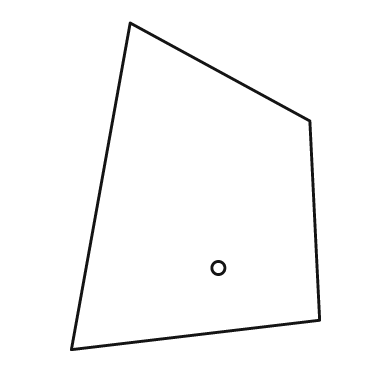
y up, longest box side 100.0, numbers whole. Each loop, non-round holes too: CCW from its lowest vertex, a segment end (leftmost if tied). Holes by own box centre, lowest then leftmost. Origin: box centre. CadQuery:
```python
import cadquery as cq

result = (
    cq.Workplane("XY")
    .moveTo(-38.0, -50.0)
    .lineTo(38.0, -41.0)
    .lineTo(35.0, 20.0)
    .lineTo(-20.0, 50.0)
    .close()
    .moveTo(7.0, -25.0)
    .circle(2.0)
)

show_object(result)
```